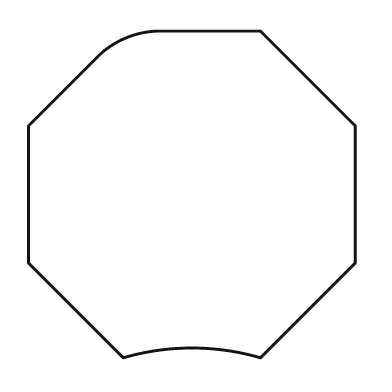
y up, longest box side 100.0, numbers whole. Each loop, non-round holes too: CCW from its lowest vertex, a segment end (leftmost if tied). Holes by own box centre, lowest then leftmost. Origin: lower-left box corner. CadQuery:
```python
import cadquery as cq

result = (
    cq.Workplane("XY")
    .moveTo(29.0, 0.0)
    .threePointArc((50.0, 3.0), (71.0, 0.0))
    .lineTo(100.0, 29.0)
    .lineTo(100.0, 71.0)
    .lineTo(71.0, 100.0)
    .lineTo(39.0, 100.0)
    .threePointArc((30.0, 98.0), (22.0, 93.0))
    .lineTo(0.0, 71.0)
    .lineTo(0.0, 29.0)
    .close()
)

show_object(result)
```